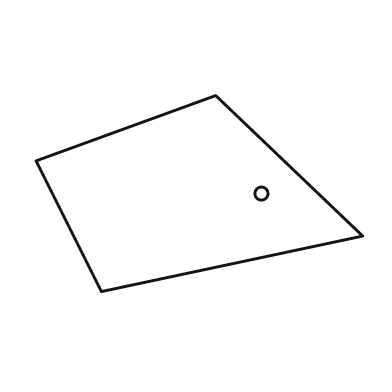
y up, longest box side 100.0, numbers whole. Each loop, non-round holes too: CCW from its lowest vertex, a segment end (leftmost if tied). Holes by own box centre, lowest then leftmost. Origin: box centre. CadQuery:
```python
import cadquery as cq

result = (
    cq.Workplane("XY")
    .moveTo(-30.0, -30.0)
    .lineTo(50.0, -13.0)
    .lineTo(5.0, 30.0)
    .lineTo(-50.0, 10.0)
    .close()
    .moveTo(19.0, 0.0)
    .circle(2.0)
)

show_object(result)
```